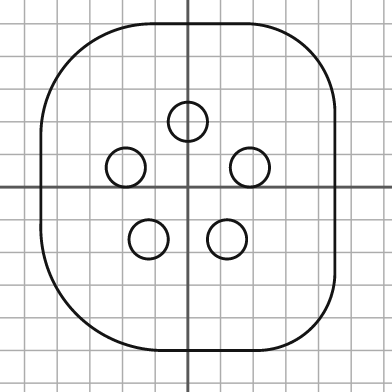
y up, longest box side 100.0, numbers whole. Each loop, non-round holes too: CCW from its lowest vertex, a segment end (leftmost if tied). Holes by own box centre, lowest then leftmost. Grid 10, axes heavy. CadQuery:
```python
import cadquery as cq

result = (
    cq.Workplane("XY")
    .moveTo(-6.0, -50.0)
    .lineTo(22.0, -50.0)
    .threePointArc((38.0, -43.0), (45.0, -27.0))
    .lineTo(45.0, 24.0)
    .threePointArc((37.0, 42.0), (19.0, 50.0))
    .lineTo(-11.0, 50.0)
    .threePointArc((-35.0, 40.0), (-45.0, 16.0))
    .lineTo(-45.0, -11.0)
    .threePointArc((-34.0, -39.0), (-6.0, -50.0))
    .close()
    .moveTo(-12.0, -16.0)
    .circle(6.0)
    .moveTo(12.0, -16.0)
    .circle(6.0)
    .moveTo(-19.0, 6.0)
    .circle(6.0)
    .moveTo(19.0, 6.0)
    .circle(6.0)
    .moveTo(0.0, 20.0)
    .circle(6.0)
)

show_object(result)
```